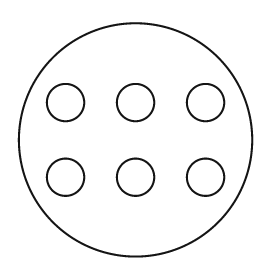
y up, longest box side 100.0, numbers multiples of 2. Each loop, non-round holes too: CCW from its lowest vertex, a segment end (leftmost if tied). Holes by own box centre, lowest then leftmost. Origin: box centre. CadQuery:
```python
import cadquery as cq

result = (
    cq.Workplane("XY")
    .moveTo(0.0, 0.0)
    .circle(50.0)
    .moveTo(-30.0, -16.0)
    .circle(8.0)
    .moveTo(0.0, -16.0)
    .circle(8.0)
    .moveTo(30.0, -16.0)
    .circle(8.0)
    .moveTo(-30.0, 16.0)
    .circle(8.0)
    .moveTo(0.0, 16.0)
    .circle(8.0)
    .moveTo(30.0, 16.0)
    .circle(8.0)
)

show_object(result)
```